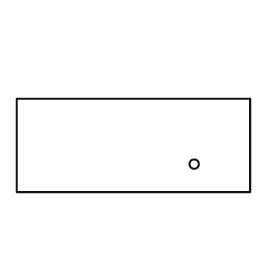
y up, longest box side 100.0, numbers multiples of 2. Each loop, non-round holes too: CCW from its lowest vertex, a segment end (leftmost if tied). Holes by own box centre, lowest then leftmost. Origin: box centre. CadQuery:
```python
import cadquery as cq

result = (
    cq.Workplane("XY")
    .moveTo(-50.0, -20.0)
    .lineTo(50.0, -20.0)
    .lineTo(50.0, 20.0)
    .lineTo(-50.0, 20.0)
    .close()
    .moveTo(26.0, -8.0)
    .circle(2.0)
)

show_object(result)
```